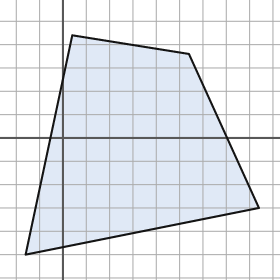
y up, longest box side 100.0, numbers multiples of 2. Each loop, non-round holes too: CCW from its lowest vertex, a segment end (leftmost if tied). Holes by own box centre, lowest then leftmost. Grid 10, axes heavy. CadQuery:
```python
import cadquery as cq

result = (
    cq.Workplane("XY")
    .moveTo(-16.0, -50.0)
    .lineTo(84.0, -30.0)
    .lineTo(54.0, 36.0)
    .lineTo(4.0, 44.0)
    .close()
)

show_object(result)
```